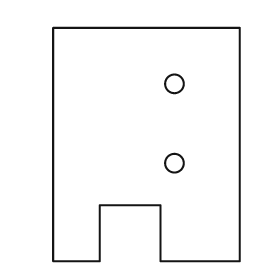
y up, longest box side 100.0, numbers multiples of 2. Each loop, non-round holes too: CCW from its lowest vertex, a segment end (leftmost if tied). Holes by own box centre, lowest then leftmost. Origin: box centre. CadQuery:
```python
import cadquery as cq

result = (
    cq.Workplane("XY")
    .moveTo(-40.0, -50.0)
    .lineTo(-20.0, -50.0)
    .lineTo(-20.0, -26.0)
    .lineTo(6.0, -26.0)
    .lineTo(6.0, -50.0)
    .lineTo(40.0, -50.0)
    .lineTo(40.0, 50.0)
    .lineTo(-40.0, 50.0)
    .close()
    .moveTo(12.0, -8.0)
    .circle(4.0)
    .moveTo(12.0, 26.0)
    .circle(4.0)
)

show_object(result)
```